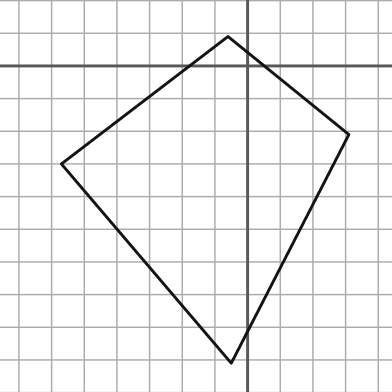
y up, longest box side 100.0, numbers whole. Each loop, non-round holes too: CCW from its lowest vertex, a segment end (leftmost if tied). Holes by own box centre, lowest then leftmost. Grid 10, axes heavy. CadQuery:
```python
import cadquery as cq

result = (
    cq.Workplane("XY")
    .moveTo(-5.0, -91.0)
    .lineTo(31.0, -21.0)
    .lineTo(-6.0, 9.0)
    .lineTo(-57.0, -30.0)
    .close()
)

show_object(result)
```